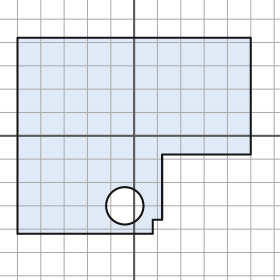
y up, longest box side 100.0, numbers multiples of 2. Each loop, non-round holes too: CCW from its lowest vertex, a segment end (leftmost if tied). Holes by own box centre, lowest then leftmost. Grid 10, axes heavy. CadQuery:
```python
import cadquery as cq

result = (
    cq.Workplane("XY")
    .moveTo(-50.0, -42.0)
    .lineTo(8.0, -42.0)
    .lineTo(8.0, -36.0)
    .lineTo(12.0, -36.0)
    .lineTo(12.0, -8.0)
    .lineTo(50.0, -8.0)
    .lineTo(50.0, 42.0)
    .lineTo(-50.0, 42.0)
    .close()
    .moveTo(-4.0, -30.0)
    .circle(8.0)
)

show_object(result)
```